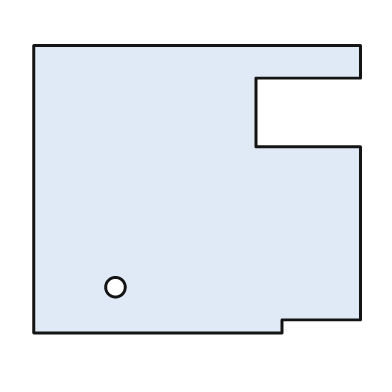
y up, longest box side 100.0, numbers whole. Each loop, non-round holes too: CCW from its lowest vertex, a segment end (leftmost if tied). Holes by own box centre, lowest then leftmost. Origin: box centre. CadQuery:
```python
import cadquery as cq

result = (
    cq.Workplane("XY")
    .moveTo(-50.0, -44.0)
    .lineTo(26.0, -44.0)
    .lineTo(26.0, -40.0)
    .lineTo(50.0, -40.0)
    .lineTo(50.0, 13.0)
    .lineTo(18.0, 13.0)
    .lineTo(18.0, 34.0)
    .lineTo(50.0, 34.0)
    .lineTo(50.0, 44.0)
    .lineTo(-50.0, 44.0)
    .close()
    .moveTo(-25.0, -30.0)
    .circle(3.0)
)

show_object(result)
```